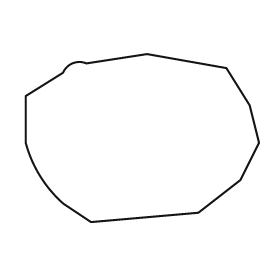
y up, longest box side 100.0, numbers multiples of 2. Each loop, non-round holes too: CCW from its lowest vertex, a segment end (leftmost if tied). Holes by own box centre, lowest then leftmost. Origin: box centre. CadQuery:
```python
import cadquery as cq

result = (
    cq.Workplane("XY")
    .moveTo(-22.0, -36.0)
    .lineTo(24.0, -32.0)
    .lineTo(42.0, -18.0)
    .lineTo(50.0, -2.0)
    .lineTo(46.0, 14.0)
    .lineTo(36.0, 30.0)
    .lineTo(2.0, 36.0)
    .lineTo(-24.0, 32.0)
    .threePointArc((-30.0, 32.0), (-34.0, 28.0))
    .lineTo(-50.0, 18.0)
    .lineTo(-50.0, -2.0)
    .threePointArc((-44.0, -16.0), (-34.0, -28.0))
    .close()
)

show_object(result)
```